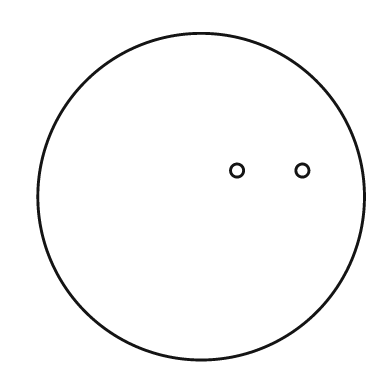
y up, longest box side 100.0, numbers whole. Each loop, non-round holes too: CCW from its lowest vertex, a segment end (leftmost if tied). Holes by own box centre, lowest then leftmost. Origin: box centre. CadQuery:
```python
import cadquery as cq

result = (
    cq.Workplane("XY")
    .moveTo(0.0, 0.0)
    .circle(50.0)
    .moveTo(11.0, 8.0)
    .circle(2.0)
    .moveTo(31.0, 8.0)
    .circle(2.0)
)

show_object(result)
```